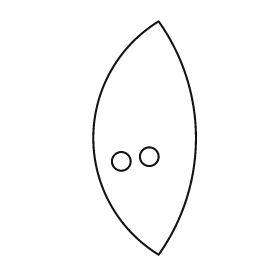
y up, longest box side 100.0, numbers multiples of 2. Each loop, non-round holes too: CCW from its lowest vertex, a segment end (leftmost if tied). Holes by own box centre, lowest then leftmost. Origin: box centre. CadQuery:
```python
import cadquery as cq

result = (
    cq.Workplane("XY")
    .moveTo(6.0, -50.0)
    .threePointArc((22.0, 0.0), (6.0, 50.0))
    .threePointArc((-22.0, 0.0), (6.0, -50.0))
    .close()
    .moveTo(-10.0, -10.0)
    .circle(4.0)
    .moveTo(2.0, -8.0)
    .circle(4.0)
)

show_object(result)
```